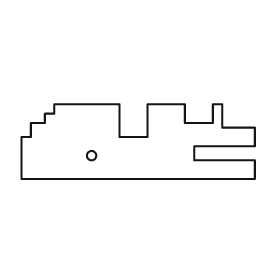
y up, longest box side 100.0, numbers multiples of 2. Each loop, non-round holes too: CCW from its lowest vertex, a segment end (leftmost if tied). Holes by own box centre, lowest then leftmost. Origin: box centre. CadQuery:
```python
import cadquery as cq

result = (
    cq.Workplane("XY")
    .moveTo(-50.0, -16.0)
    .lineTo(50.0, -16.0)
    .lineTo(50.0, -8.0)
    .lineTo(24.0, -8.0)
    .lineTo(24.0, -2.0)
    .lineTo(50.0, -2.0)
    .lineTo(50.0, 6.0)
    .lineTo(36.0, 6.0)
    .lineTo(36.0, 16.0)
    .lineTo(32.0, 16.0)
    .lineTo(32.0, 8.0)
    .lineTo(20.0, 8.0)
    .lineTo(20.0, 16.0)
    .lineTo(4.0, 16.0)
    .lineTo(4.0, 2.0)
    .lineTo(-8.0, 2.0)
    .lineTo(-8.0, 16.0)
    .lineTo(-36.0, 16.0)
    .lineTo(-36.0, 12.0)
    .lineTo(-40.0, 12.0)
    .lineTo(-40.0, 8.0)
    .lineTo(-46.0, 8.0)
    .lineTo(-46.0, 2.0)
    .lineTo(-50.0, 2.0)
    .close()
    .moveTo(-20.0, -6.0)
    .circle(2.0)
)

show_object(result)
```